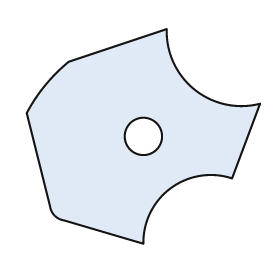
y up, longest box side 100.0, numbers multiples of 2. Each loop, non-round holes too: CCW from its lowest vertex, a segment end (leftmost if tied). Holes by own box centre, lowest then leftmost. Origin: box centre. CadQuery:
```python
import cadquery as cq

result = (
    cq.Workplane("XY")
    .moveTo(0.0, -46.0)
    .threePointArc((12.0, -22.0), (38.0, -18.0))
    .lineTo(50.0, 14.0)
    .threePointArc((22.0, 20.0), (10.0, 46.0))
    .lineTo(-32.0, 32.0)
    .threePointArc((-42.0, 22.0), (-50.0, 10.0))
    .lineTo(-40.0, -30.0)
    .threePointArc((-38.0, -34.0), (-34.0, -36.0))
    .close()
    .moveTo(0.0, 0.0)
    .circle(8.0)
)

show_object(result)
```